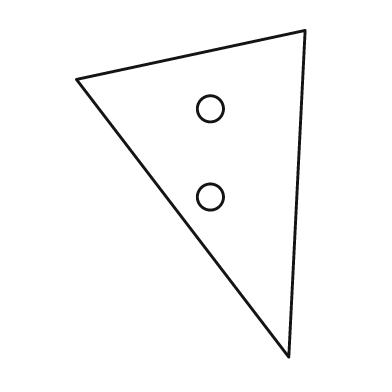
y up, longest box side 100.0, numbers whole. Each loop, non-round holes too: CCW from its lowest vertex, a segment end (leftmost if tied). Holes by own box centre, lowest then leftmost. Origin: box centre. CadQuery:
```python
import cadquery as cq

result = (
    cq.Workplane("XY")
    .moveTo(30.0, -50.0)
    .lineTo(35.0, 50.0)
    .lineTo(-35.0, 35.0)
    .close()
    .moveTo(6.0, -1.0)
    .circle(4.0)
    .moveTo(6.0, 26.0)
    .circle(4.0)
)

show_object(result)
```